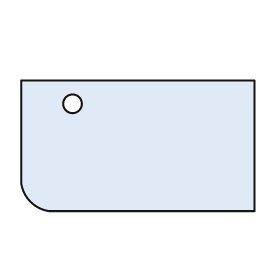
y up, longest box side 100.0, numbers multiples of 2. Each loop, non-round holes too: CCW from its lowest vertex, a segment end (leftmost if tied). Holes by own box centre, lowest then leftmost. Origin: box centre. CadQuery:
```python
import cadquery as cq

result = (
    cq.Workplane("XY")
    .moveTo(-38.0, -28.0)
    .lineTo(50.0, -28.0)
    .lineTo(50.0, 28.0)
    .lineTo(-50.0, 28.0)
    .lineTo(-50.0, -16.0)
    .threePointArc((-46.0, -24.0), (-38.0, -28.0))
    .close()
    .moveTo(-28.0, 18.0)
    .circle(4.0)
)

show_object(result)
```